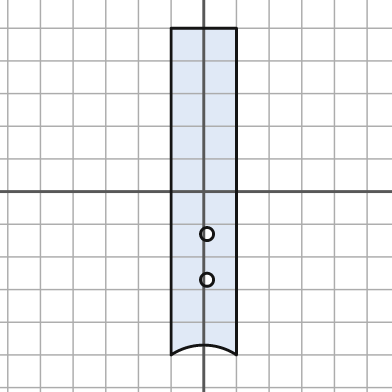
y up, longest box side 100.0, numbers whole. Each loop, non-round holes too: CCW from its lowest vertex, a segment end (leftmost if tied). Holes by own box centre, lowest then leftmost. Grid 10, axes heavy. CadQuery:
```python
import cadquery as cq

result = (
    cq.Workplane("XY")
    .moveTo(-10.0, -50.0)
    .threePointArc((0.0, -47.0), (10.0, -50.0))
    .lineTo(10.0, 50.0)
    .lineTo(-10.0, 50.0)
    .close()
    .moveTo(1.0, -27.0)
    .circle(2.0)
    .moveTo(1.0, -13.0)
    .circle(2.0)
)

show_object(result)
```